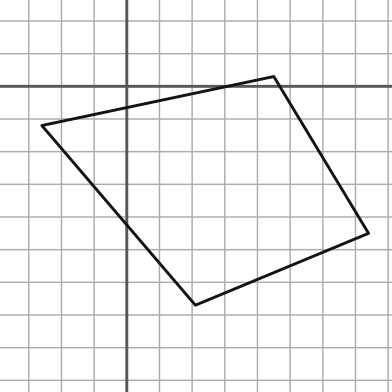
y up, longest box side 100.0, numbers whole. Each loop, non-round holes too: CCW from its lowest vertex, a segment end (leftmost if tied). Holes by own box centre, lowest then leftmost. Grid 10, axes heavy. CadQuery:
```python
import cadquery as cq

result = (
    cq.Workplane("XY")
    .moveTo(21.0, -67.0)
    .lineTo(74.0, -45.0)
    .lineTo(45.0, 3.0)
    .lineTo(-26.0, -12.0)
    .close()
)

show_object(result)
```